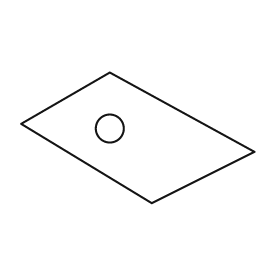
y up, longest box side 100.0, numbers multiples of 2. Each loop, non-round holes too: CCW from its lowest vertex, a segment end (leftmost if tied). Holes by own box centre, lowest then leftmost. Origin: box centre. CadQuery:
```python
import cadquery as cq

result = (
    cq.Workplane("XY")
    .moveTo(6.0, -28.0)
    .lineTo(50.0, -6.0)
    .lineTo(-12.0, 28.0)
    .lineTo(-50.0, 6.0)
    .close()
    .moveTo(-12.0, 4.0)
    .circle(6.0)
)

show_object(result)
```